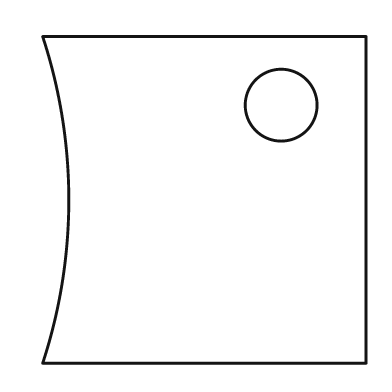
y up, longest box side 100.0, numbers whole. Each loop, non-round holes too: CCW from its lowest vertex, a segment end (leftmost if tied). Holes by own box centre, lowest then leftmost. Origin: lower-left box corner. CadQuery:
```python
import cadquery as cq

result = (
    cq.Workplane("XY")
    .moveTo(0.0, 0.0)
    .lineTo(99.0, 0.0)
    .lineTo(99.0, 100.0)
    .lineTo(0.0, 100.0)
    .threePointArc((8.0, 50.0), (0.0, 0.0))
    .close()
    .moveTo(73.0, 79.0)
    .circle(11.0)
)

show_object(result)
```